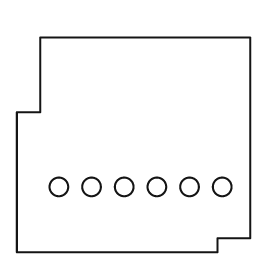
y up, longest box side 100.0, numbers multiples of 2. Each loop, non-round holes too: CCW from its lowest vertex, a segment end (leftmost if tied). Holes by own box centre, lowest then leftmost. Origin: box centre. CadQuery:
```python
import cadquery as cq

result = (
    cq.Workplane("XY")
    .moveTo(-50.0, -46.0)
    .lineTo(36.0, -46.0)
    .lineTo(36.0, -40.0)
    .lineTo(50.0, -40.0)
    .lineTo(50.0, 46.0)
    .lineTo(-40.0, 46.0)
    .lineTo(-40.0, 14.0)
    .lineTo(-50.0, 14.0)
    .close()
    .moveTo(-32.0, -18.0)
    .circle(4.0)
    .moveTo(-18.0, -18.0)
    .circle(4.0)
    .moveTo(-4.0, -18.0)
    .circle(4.0)
    .moveTo(10.0, -18.0)
    .circle(4.0)
    .moveTo(24.0, -18.0)
    .circle(4.0)
    .moveTo(38.0, -18.0)
    .circle(4.0)
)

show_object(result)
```